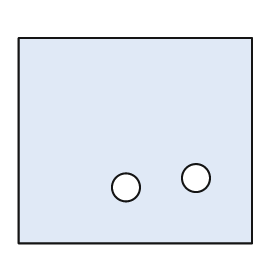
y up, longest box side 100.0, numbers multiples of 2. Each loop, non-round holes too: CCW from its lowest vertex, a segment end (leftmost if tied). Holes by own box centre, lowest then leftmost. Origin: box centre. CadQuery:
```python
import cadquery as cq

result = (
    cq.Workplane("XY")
    .moveTo(-50.0, -44.0)
    .lineTo(50.0, -44.0)
    .lineTo(50.0, 44.0)
    .lineTo(-50.0, 44.0)
    .close()
    .moveTo(-4.0, -20.0)
    .circle(6.0)
    .moveTo(26.0, -16.0)
    .circle(6.0)
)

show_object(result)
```